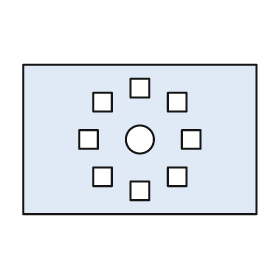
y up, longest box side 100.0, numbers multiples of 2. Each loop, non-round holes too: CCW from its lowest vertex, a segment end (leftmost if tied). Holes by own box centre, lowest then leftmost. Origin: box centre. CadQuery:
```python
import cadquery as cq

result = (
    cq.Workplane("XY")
    .moveTo(-50.0, -32.0)
    .lineTo(50.0, -32.0)
    .lineTo(50.0, 32.0)
    .lineTo(-50.0, 32.0)
    .close()
    .moveTo(-4.0, -26.0)
    .lineTo(4.0, -26.0)
    .lineTo(4.0, -18.0)
    .lineTo(-4.0, -18.0)
    .close()
    .moveTo(-20.0, -20.0)
    .lineTo(-12.0, -20.0)
    .lineTo(-12.0, -12.0)
    .lineTo(-20.0, -12.0)
    .close()
    .moveTo(12.0, -20.0)
    .lineTo(20.0, -20.0)
    .lineTo(20.0, -12.0)
    .lineTo(12.0, -12.0)
    .close()
    .moveTo(-26.0, -4.0)
    .lineTo(-18.0, -4.0)
    .lineTo(-18.0, 4.0)
    .lineTo(-26.0, 4.0)
    .close()
    .moveTo(0.0, 0.0)
    .circle(6.0)
    .moveTo(18.0, -4.0)
    .lineTo(26.0, -4.0)
    .lineTo(26.0, 4.0)
    .lineTo(18.0, 4.0)
    .close()
    .moveTo(-20.0, 12.0)
    .lineTo(-12.0, 12.0)
    .lineTo(-12.0, 20.0)
    .lineTo(-20.0, 20.0)
    .close()
    .moveTo(12.0, 12.0)
    .lineTo(20.0, 12.0)
    .lineTo(20.0, 20.0)
    .lineTo(12.0, 20.0)
    .close()
    .moveTo(-4.0, 18.0)
    .lineTo(4.0, 18.0)
    .lineTo(4.0, 26.0)
    .lineTo(-4.0, 26.0)
    .close()
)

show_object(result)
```